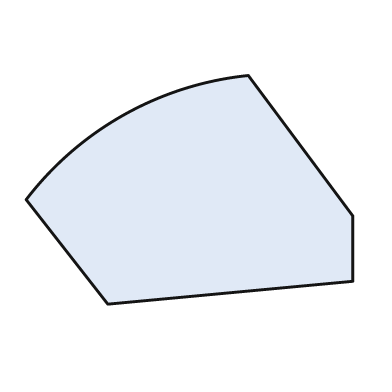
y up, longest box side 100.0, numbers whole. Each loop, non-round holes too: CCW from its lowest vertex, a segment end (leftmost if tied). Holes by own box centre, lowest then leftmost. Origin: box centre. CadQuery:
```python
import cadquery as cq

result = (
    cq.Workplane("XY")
    .moveTo(-25.0, -35.0)
    .lineTo(50.0, -28.0)
    .lineTo(50.0, -8.0)
    .lineTo(18.0, 35.0)
    .threePointArc((-20.0, 23.0), (-50.0, -3.0))
    .close()
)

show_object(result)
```